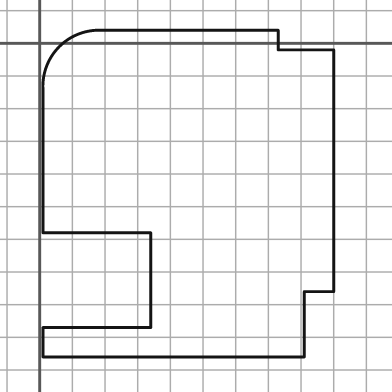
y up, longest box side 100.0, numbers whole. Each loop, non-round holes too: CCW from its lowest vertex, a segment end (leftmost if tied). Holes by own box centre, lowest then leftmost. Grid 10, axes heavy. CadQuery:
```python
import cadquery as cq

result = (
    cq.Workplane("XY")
    .moveTo(1.0, -96.0)
    .lineTo(81.0, -96.0)
    .lineTo(81.0, -76.0)
    .lineTo(90.0, -76.0)
    .lineTo(90.0, -2.0)
    .lineTo(73.0, -2.0)
    .lineTo(73.0, 4.0)
    .lineTo(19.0, 4.0)
    .threePointArc((6.0, -1.0), (1.0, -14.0))
    .lineTo(1.0, -58.0)
    .lineTo(34.0, -58.0)
    .lineTo(34.0, -87.0)
    .lineTo(1.0, -87.0)
    .close()
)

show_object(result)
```